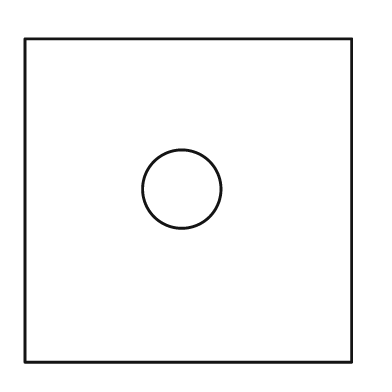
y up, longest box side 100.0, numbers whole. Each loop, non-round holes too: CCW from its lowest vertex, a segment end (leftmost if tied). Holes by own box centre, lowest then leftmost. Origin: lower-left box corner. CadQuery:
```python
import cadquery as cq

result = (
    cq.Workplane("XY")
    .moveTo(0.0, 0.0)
    .lineTo(100.0, 0.0)
    .lineTo(100.0, 99.0)
    .lineTo(0.0, 99.0)
    .close()
    .moveTo(48.0, 53.0)
    .circle(12.0)
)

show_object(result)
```